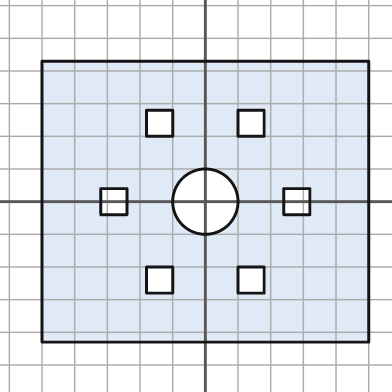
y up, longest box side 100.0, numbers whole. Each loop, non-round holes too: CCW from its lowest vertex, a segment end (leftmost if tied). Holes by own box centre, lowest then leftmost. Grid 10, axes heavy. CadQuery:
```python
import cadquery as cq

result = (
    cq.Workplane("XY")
    .moveTo(-50.0, -43.0)
    .lineTo(50.0, -43.0)
    .lineTo(50.0, 43.0)
    .lineTo(-50.0, 43.0)
    .close()
    .moveTo(-18.0, -28.0)
    .lineTo(-10.0, -28.0)
    .lineTo(-10.0, -20.0)
    .lineTo(-18.0, -20.0)
    .close()
    .moveTo(10.0, -28.0)
    .lineTo(18.0, -28.0)
    .lineTo(18.0, -20.0)
    .lineTo(10.0, -20.0)
    .close()
    .moveTo(-32.0, -4.0)
    .lineTo(-24.0, -4.0)
    .lineTo(-24.0, 4.0)
    .lineTo(-32.0, 4.0)
    .close()
    .moveTo(0.0, 0.0)
    .circle(10.0)
    .moveTo(24.0, -4.0)
    .lineTo(32.0, -4.0)
    .lineTo(32.0, 4.0)
    .lineTo(24.0, 4.0)
    .close()
    .moveTo(-18.0, 20.0)
    .lineTo(-10.0, 20.0)
    .lineTo(-10.0, 28.0)
    .lineTo(-18.0, 28.0)
    .close()
    .moveTo(10.0, 20.0)
    .lineTo(18.0, 20.0)
    .lineTo(18.0, 28.0)
    .lineTo(10.0, 28.0)
    .close()
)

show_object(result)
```